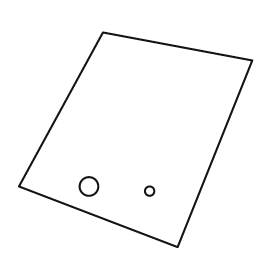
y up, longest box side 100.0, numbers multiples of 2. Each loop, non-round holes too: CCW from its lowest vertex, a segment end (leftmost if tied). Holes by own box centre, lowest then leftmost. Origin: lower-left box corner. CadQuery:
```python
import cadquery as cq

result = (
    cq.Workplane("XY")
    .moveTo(68.0, 0.0)
    .lineTo(100.0, 80.0)
    .lineTo(36.0, 92.0)
    .lineTo(0.0, 26.0)
    .close()
    .moveTo(56.0, 24.0)
    .circle(2.0)
    .moveTo(30.0, 26.0)
    .circle(4.0)
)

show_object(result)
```